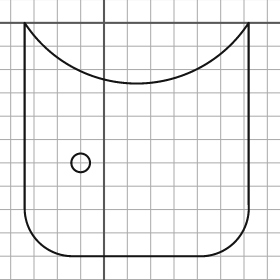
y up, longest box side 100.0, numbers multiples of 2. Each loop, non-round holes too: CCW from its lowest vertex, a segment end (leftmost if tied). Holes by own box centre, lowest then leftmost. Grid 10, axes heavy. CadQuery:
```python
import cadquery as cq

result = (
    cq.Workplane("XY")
    .moveTo(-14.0, -100.0)
    .lineTo(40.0, -100.0)
    .threePointArc((56.0, -94.0), (62.0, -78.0))
    .lineTo(62.0, 0.0)
    .threePointArc((14.0, -26.0), (-34.0, 0.0))
    .lineTo(-34.0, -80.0)
    .threePointArc((-28.0, -94.0), (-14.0, -100.0))
    .close()
    .moveTo(-10.0, -60.0)
    .circle(4.0)
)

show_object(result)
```